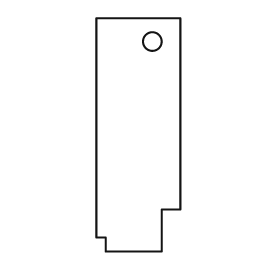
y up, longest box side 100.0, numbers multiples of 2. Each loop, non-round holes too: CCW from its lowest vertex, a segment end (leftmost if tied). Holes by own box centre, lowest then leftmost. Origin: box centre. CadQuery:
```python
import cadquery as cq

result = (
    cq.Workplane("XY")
    .moveTo(-14.0, -50.0)
    .lineTo(10.0, -50.0)
    .lineTo(10.0, -32.0)
    .lineTo(18.0, -32.0)
    .lineTo(18.0, 50.0)
    .lineTo(-18.0, 50.0)
    .lineTo(-18.0, -44.0)
    .lineTo(-14.0, -44.0)
    .close()
    .moveTo(6.0, 40.0)
    .circle(4.0)
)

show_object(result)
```